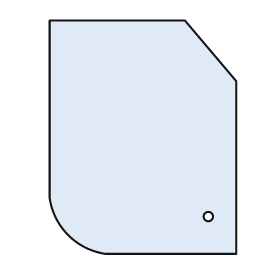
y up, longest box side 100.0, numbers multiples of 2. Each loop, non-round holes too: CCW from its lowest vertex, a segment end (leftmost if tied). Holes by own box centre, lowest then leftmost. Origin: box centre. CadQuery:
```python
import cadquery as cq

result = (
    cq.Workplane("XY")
    .moveTo(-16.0, -50.0)
    .lineTo(40.0, -50.0)
    .lineTo(40.0, 24.0)
    .lineTo(18.0, 50.0)
    .lineTo(-40.0, 50.0)
    .lineTo(-40.0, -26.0)
    .threePointArc((-32.0, -42.0), (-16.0, -50.0))
    .close()
    .moveTo(28.0, -34.0)
    .circle(2.0)
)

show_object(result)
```